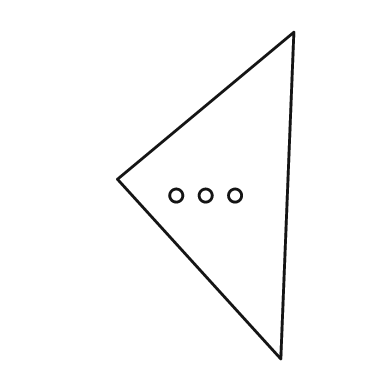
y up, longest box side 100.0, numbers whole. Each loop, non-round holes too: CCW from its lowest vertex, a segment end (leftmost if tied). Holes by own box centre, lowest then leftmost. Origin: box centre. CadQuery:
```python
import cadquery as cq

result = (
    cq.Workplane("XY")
    .moveTo(23.0, -50.0)
    .lineTo(27.0, 50.0)
    .lineTo(-27.0, 5.0)
    .close()
    .moveTo(-9.0, 0.0)
    .circle(2.0)
    .moveTo(0.0, 0.0)
    .circle(2.0)
    .moveTo(9.0, 0.0)
    .circle(2.0)
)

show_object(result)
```